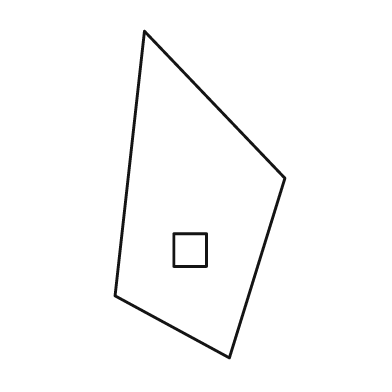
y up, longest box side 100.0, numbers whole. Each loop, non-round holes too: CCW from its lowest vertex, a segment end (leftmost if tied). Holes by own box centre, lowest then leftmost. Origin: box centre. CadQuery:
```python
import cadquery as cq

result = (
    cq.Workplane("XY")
    .moveTo(9.0, -50.0)
    .lineTo(26.0, 5.0)
    .lineTo(-17.0, 50.0)
    .lineTo(-26.0, -31.0)
    .close()
    .moveTo(-8.0, -22.0)
    .lineTo(2.0, -22.0)
    .lineTo(2.0, -12.0)
    .lineTo(-8.0, -12.0)
    .close()
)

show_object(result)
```